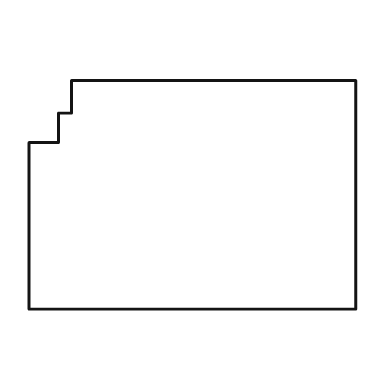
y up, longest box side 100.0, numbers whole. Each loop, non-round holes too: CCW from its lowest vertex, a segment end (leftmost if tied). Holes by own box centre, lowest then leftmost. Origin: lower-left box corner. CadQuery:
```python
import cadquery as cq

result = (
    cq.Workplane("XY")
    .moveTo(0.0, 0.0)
    .lineTo(100.0, 0.0)
    .lineTo(100.0, 70.0)
    .lineTo(13.0, 70.0)
    .lineTo(13.0, 60.0)
    .lineTo(9.0, 60.0)
    .lineTo(9.0, 51.0)
    .lineTo(0.0, 51.0)
    .close()
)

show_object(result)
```